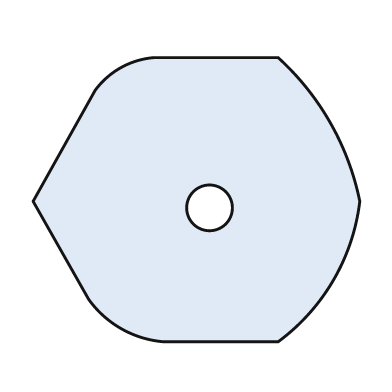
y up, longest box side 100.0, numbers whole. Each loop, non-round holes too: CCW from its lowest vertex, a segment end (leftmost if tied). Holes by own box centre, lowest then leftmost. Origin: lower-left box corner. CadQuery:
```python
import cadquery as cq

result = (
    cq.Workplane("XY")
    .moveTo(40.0, 0.0)
    .lineTo(75.0, 0.0)
    .threePointArc((92.0, 19.0), (100.0, 43.0))
    .threePointArc((91.0, 67.0), (75.0, 87.0))
    .lineTo(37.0, 87.0)
    .threePointArc((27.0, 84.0), (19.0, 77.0))
    .lineTo(0.0, 43.0)
    .lineTo(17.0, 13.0)
    .threePointArc((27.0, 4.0), (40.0, 0.0))
    .close()
    .moveTo(54.0, 41.0)
    .circle(7.0)
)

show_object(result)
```